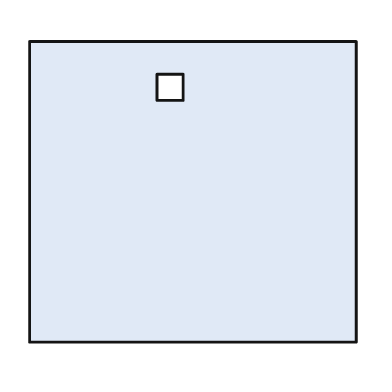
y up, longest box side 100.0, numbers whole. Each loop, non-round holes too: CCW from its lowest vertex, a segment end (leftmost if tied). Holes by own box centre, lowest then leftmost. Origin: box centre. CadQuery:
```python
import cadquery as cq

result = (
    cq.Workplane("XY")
    .moveTo(-50.0, -46.0)
    .lineTo(50.0, -46.0)
    .lineTo(50.0, 46.0)
    .lineTo(-50.0, 46.0)
    .close()
    .moveTo(-11.0, 28.0)
    .lineTo(-3.0, 28.0)
    .lineTo(-3.0, 36.0)
    .lineTo(-11.0, 36.0)
    .close()
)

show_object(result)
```